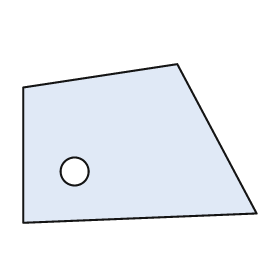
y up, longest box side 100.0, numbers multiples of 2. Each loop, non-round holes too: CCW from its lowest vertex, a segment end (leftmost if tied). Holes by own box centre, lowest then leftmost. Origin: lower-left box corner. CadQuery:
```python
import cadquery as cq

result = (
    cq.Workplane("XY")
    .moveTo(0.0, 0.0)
    .lineTo(100.0, 4.0)
    .lineTo(66.0, 68.0)
    .lineTo(0.0, 58.0)
    .close()
    .moveTo(22.0, 22.0)
    .circle(6.0)
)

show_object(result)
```